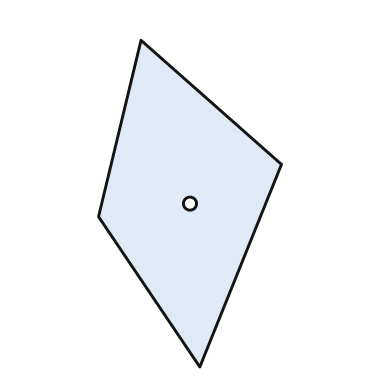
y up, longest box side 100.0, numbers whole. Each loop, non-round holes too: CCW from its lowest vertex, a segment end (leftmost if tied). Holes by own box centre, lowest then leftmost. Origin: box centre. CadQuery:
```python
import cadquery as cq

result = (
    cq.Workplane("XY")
    .moveTo(3.0, -50.0)
    .lineTo(28.0, 12.0)
    .lineTo(-15.0, 50.0)
    .lineTo(-28.0, -4.0)
    .close()
    .moveTo(0.0, 0.0)
    .circle(2.0)
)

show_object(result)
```